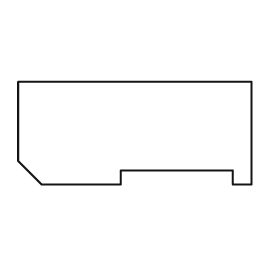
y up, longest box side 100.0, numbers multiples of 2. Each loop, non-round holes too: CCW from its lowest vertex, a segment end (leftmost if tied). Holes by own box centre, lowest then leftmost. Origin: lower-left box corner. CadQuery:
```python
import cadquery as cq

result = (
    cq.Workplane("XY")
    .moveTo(10.0, 0.0)
    .lineTo(44.0, 0.0)
    .lineTo(44.0, 6.0)
    .lineTo(92.0, 6.0)
    .lineTo(92.0, 0.0)
    .lineTo(100.0, 0.0)
    .lineTo(100.0, 44.0)
    .lineTo(0.0, 44.0)
    .lineTo(0.0, 10.0)
    .close()
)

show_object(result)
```